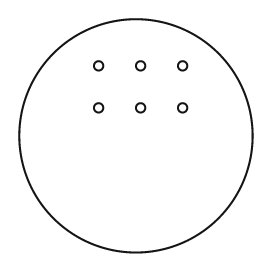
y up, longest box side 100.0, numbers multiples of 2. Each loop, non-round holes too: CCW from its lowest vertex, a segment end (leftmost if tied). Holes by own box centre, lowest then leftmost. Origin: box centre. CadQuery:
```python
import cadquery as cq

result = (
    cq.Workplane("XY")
    .moveTo(0.0, 0.0)
    .circle(50.0)
    .moveTo(-16.0, 12.0)
    .circle(2.0)
    .moveTo(2.0, 12.0)
    .circle(2.0)
    .moveTo(20.0, 12.0)
    .circle(2.0)
    .moveTo(-16.0, 30.0)
    .circle(2.0)
    .moveTo(2.0, 30.0)
    .circle(2.0)
    .moveTo(20.0, 30.0)
    .circle(2.0)
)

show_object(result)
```